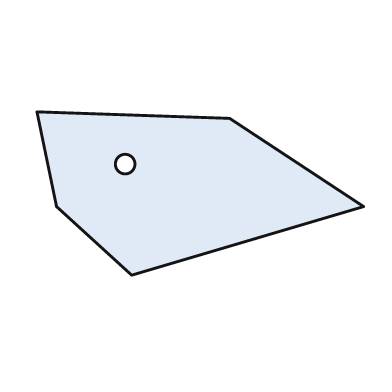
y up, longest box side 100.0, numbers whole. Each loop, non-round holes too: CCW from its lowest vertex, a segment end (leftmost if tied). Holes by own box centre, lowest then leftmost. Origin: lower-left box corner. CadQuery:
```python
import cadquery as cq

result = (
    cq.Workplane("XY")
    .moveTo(29.0, 0.0)
    .lineTo(100.0, 21.0)
    .lineTo(59.0, 48.0)
    .lineTo(0.0, 50.0)
    .lineTo(6.0, 21.0)
    .close()
    .moveTo(27.0, 34.0)
    .circle(3.0)
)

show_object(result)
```